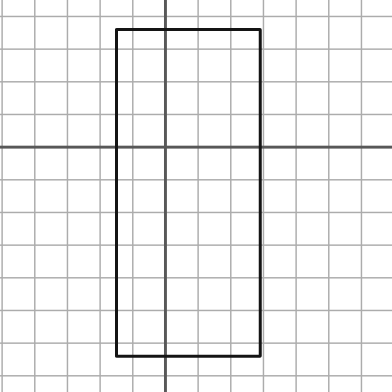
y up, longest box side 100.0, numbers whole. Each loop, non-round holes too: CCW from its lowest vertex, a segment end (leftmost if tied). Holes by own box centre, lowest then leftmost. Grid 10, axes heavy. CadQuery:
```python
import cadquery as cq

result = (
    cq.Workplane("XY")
    .moveTo(-15.0, -64.0)
    .lineTo(29.0, -64.0)
    .lineTo(29.0, 36.0)
    .lineTo(-15.0, 36.0)
    .close()
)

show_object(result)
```